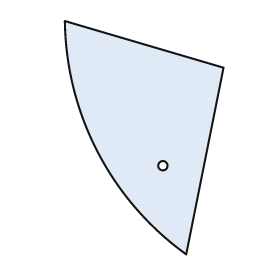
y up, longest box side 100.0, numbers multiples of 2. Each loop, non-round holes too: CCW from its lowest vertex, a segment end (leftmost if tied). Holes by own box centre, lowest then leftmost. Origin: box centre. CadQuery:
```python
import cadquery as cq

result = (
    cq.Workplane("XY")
    .moveTo(18.0, -50.0)
    .lineTo(34.0, 30.0)
    .lineTo(-34.0, 50.0)
    .threePointArc((-20.0, -6.0), (18.0, -50.0))
    .close()
    .moveTo(8.0, -12.0)
    .circle(2.0)
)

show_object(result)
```